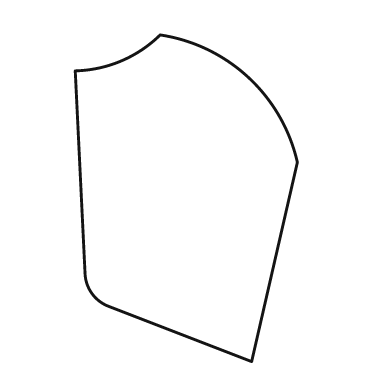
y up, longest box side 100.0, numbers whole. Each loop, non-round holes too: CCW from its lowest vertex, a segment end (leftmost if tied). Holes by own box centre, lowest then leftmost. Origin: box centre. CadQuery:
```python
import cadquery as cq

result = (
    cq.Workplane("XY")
    .moveTo(20.0, -50.0)
    .lineTo(34.0, 11.0)
    .threePointArc((19.0, 37.0), (-8.0, 50.0))
    .threePointArc((-20.0, 42.0), (-34.0, 39.0))
    .lineTo(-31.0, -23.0)
    .threePointArc((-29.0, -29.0), (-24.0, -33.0))
    .close()
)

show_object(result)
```